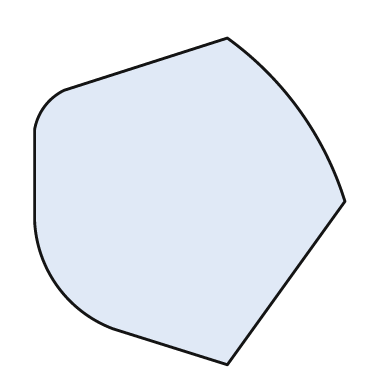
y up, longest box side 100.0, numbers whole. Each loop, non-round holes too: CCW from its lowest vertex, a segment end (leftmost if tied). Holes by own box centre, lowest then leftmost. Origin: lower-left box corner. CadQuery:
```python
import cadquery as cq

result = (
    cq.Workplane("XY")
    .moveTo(59.0, 0.0)
    .lineTo(95.0, 50.0)
    .threePointArc((81.0, 78.0), (59.0, 100.0))
    .lineTo(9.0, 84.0)
    .threePointArc((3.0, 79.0), (0.0, 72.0))
    .lineTo(0.0, 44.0)
    .threePointArc((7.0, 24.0), (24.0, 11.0))
    .close()
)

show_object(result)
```